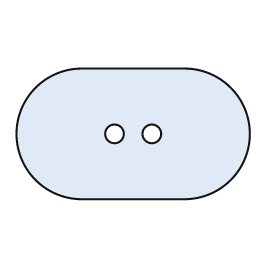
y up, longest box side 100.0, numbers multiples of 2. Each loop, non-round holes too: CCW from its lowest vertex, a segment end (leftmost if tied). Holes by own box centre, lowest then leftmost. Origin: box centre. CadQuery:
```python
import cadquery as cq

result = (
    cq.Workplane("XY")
    .moveTo(-22.0, -28.0)
    .lineTo(22.0, -28.0)
    .threePointArc((50.0, 0.0), (22.0, 28.0))
    .lineTo(-22.0, 28.0)
    .threePointArc((-50.0, 0.0), (-22.0, -28.0))
    .close()
    .moveTo(-8.0, 0.0)
    .circle(4.0)
    .moveTo(8.0, 0.0)
    .circle(4.0)
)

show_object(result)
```